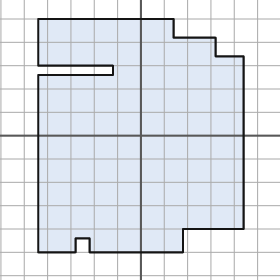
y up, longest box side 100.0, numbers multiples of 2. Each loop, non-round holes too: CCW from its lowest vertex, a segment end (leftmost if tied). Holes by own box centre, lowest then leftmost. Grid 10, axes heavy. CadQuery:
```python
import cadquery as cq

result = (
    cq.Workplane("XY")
    .moveTo(-44.0, -50.0)
    .lineTo(-28.0, -50.0)
    .lineTo(-28.0, -44.0)
    .lineTo(-22.0, -44.0)
    .lineTo(-22.0, -50.0)
    .lineTo(18.0, -50.0)
    .lineTo(18.0, -40.0)
    .lineTo(44.0, -40.0)
    .lineTo(44.0, 34.0)
    .lineTo(32.0, 34.0)
    .lineTo(32.0, 42.0)
    .lineTo(14.0, 42.0)
    .lineTo(14.0, 50.0)
    .lineTo(-44.0, 50.0)
    .lineTo(-44.0, 30.0)
    .lineTo(-12.0, 30.0)
    .lineTo(-12.0, 26.0)
    .lineTo(-44.0, 26.0)
    .close()
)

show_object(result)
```